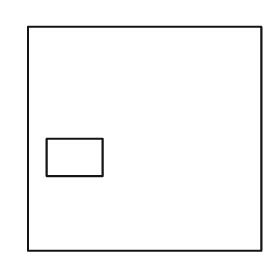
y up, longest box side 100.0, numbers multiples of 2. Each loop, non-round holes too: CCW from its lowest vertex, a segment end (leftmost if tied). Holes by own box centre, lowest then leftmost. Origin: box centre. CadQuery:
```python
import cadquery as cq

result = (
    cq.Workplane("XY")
    .moveTo(-50.0, -48.0)
    .lineTo(50.0, -48.0)
    .lineTo(50.0, 48.0)
    .lineTo(-50.0, 48.0)
    .close()
    .moveTo(-42.0, -16.0)
    .lineTo(-18.0, -16.0)
    .lineTo(-18.0, 0.0)
    .lineTo(-42.0, 0.0)
    .close()
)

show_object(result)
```